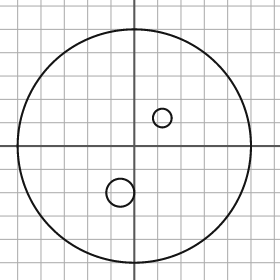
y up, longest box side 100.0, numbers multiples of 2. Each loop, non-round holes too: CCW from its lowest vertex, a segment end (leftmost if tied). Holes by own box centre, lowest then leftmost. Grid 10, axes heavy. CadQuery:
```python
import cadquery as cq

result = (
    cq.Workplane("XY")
    .moveTo(0.0, 0.0)
    .circle(50.0)
    .moveTo(-6.0, -20.0)
    .circle(6.0)
    .moveTo(12.0, 12.0)
    .circle(4.0)
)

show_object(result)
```